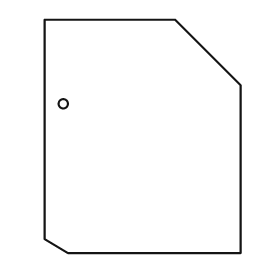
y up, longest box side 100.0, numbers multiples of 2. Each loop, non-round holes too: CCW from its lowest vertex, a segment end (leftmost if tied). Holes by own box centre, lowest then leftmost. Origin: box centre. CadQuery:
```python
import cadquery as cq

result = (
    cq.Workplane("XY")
    .moveTo(-32.0, -50.0)
    .lineTo(42.0, -50.0)
    .lineTo(42.0, 22.0)
    .lineTo(14.0, 50.0)
    .lineTo(-42.0, 50.0)
    .lineTo(-42.0, -44.0)
    .close()
    .moveTo(-34.0, 14.0)
    .circle(2.0)
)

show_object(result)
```